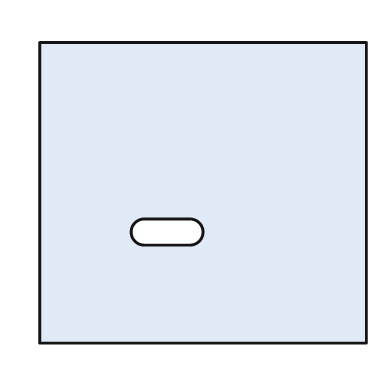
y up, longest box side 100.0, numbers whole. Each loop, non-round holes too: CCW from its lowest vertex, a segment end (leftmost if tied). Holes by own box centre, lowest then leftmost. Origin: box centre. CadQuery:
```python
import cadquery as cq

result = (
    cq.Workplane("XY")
    .moveTo(-50.0, -46.0)
    .lineTo(50.0, -46.0)
    .lineTo(50.0, 46.0)
    .lineTo(-50.0, 46.0)
    .close()
    .moveTo(-18.0, -16.0)
    .lineTo(-4.0, -16.0)
    .threePointArc((0.0, -12.0), (-4.0, -8.0))
    .lineTo(-18.0, -8.0)
    .threePointArc((-22.0, -12.0), (-18.0, -16.0))
    .close()
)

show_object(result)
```